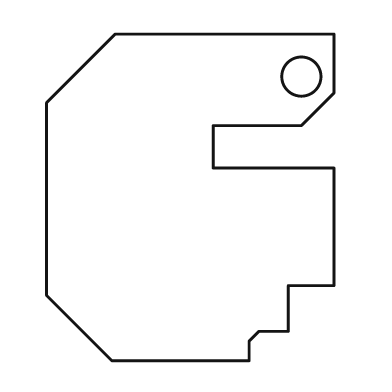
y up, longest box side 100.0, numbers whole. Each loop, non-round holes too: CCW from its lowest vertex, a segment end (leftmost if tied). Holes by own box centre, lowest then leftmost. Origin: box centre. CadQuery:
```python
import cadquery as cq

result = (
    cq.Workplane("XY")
    .moveTo(-24.0, -50.0)
    .lineTo(18.0, -50.0)
    .lineTo(18.0, -44.0)
    .lineTo(21.0, -41.0)
    .lineTo(30.0, -41.0)
    .lineTo(30.0, -27.0)
    .lineTo(44.0, -27.0)
    .lineTo(44.0, 9.0)
    .lineTo(7.0, 9.0)
    .lineTo(7.0, 22.0)
    .lineTo(34.0, 22.0)
    .lineTo(44.0, 32.0)
    .lineTo(44.0, 50.0)
    .lineTo(-23.0, 50.0)
    .lineTo(-44.0, 29.0)
    .lineTo(-44.0, -30.0)
    .close()
    .moveTo(34.0, 37.0)
    .circle(6.0)
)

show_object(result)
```